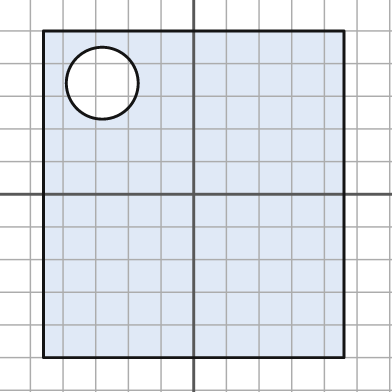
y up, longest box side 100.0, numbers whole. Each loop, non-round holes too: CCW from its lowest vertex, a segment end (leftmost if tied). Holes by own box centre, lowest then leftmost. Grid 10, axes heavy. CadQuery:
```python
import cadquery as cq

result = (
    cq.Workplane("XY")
    .moveTo(-46.0, -50.0)
    .lineTo(46.0, -50.0)
    .lineTo(46.0, 50.0)
    .lineTo(-46.0, 50.0)
    .close()
    .moveTo(-28.0, 34.0)
    .circle(11.0)
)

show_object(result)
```